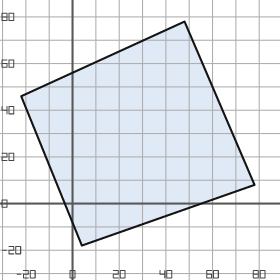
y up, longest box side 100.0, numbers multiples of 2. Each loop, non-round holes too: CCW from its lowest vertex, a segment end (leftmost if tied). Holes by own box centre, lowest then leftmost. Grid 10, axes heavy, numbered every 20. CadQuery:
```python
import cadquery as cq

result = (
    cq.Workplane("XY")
    .moveTo(4.0, -18.0)
    .lineTo(78.0, 8.0)
    .lineTo(48.0, 78.0)
    .lineTo(-22.0, 46.0)
    .close()
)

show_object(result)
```